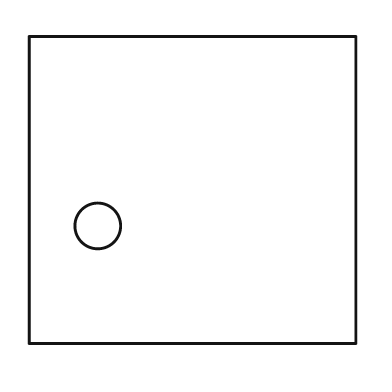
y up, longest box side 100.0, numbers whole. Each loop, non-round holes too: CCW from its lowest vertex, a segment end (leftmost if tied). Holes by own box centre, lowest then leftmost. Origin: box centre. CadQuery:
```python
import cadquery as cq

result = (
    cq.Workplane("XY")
    .moveTo(-50.0, -47.0)
    .lineTo(50.0, -47.0)
    .lineTo(50.0, 47.0)
    .lineTo(-50.0, 47.0)
    .close()
    .moveTo(-29.0, -11.0)
    .circle(7.0)
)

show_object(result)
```